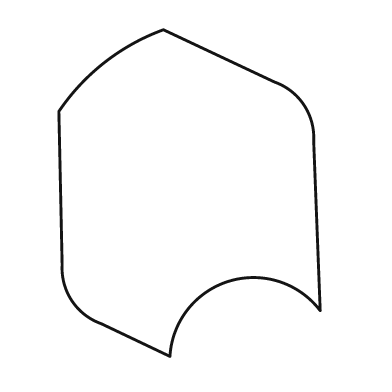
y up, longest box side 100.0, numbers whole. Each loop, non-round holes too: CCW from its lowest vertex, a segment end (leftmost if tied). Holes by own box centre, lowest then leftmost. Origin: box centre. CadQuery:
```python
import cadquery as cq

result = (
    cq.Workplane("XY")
    .moveTo(-6.0, -50.0)
    .threePointArc((12.0, -27.0), (40.0, -36.0))
    .lineTo(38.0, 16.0)
    .threePointArc((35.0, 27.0), (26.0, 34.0))
    .lineTo(-8.0, 50.0)
    .threePointArc((-26.0, 40.0), (-40.0, 25.0))
    .lineTo(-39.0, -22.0)
    .threePointArc((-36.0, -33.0), (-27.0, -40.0))
    .close()
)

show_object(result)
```